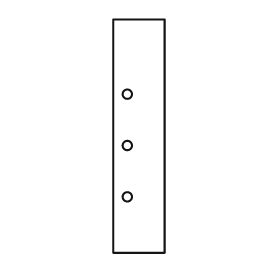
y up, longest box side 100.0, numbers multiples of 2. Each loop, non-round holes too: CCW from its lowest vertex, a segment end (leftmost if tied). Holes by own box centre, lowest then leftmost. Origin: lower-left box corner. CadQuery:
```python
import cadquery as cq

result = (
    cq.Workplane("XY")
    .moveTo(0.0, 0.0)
    .lineTo(22.0, 0.0)
    .lineTo(22.0, 100.0)
    .lineTo(0.0, 100.0)
    .close()
    .moveTo(6.0, 24.0)
    .circle(2.0)
    .moveTo(6.0, 46.0)
    .circle(2.0)
    .moveTo(6.0, 68.0)
    .circle(2.0)
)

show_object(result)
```